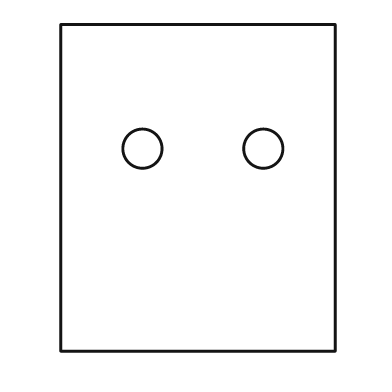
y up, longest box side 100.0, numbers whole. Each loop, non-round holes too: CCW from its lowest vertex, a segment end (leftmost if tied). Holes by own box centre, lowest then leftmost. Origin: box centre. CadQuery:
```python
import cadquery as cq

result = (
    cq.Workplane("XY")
    .moveTo(-42.0, -50.0)
    .lineTo(42.0, -50.0)
    .lineTo(42.0, 50.0)
    .lineTo(-42.0, 50.0)
    .close()
    .moveTo(-17.0, 12.0)
    .circle(6.0)
    .moveTo(20.0, 12.0)
    .circle(6.0)
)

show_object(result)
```